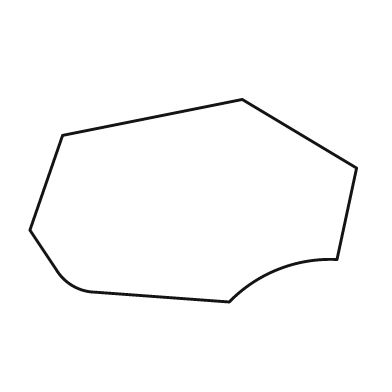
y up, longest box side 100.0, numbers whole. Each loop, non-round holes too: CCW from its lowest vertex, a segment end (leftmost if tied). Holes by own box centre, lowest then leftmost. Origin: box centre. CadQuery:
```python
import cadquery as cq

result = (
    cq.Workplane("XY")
    .moveTo(11.0, -31.0)
    .threePointArc((26.0, -21.0), (44.0, -18.0))
    .lineTo(50.0, 10.0)
    .lineTo(15.0, 31.0)
    .lineTo(-40.0, 20.0)
    .lineTo(-50.0, -9.0)
    .lineTo(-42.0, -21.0)
    .threePointArc((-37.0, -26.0), (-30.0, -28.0))
    .close()
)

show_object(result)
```